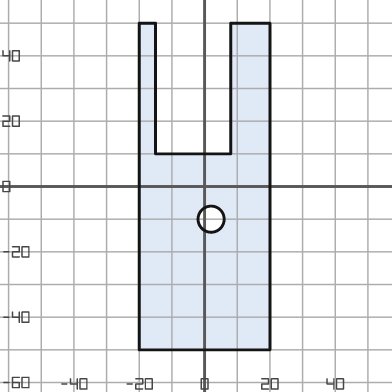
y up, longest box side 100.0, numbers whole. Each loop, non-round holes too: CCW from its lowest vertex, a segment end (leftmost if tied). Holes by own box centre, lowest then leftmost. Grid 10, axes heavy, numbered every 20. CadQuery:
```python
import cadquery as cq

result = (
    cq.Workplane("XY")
    .moveTo(-20.0, -50.0)
    .lineTo(20.0, -50.0)
    .lineTo(20.0, 50.0)
    .lineTo(8.0, 50.0)
    .lineTo(8.0, 10.0)
    .lineTo(-15.0, 10.0)
    .lineTo(-15.0, 50.0)
    .lineTo(-20.0, 50.0)
    .close()
    .moveTo(2.0, -10.0)
    .circle(4.0)
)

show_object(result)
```